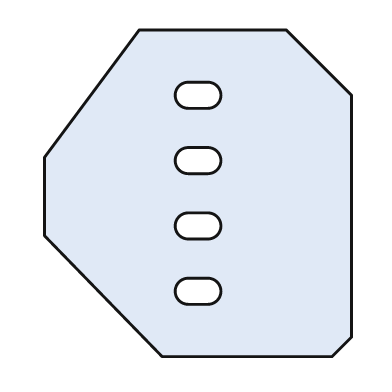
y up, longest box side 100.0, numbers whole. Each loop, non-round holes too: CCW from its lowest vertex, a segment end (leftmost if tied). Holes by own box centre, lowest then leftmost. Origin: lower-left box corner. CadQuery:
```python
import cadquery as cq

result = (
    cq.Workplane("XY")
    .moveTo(36.0, 0.0)
    .lineTo(88.0, 0.0)
    .lineTo(94.0, 6.0)
    .lineTo(94.0, 80.0)
    .lineTo(74.0, 100.0)
    .lineTo(29.0, 100.0)
    .lineTo(0.0, 61.0)
    .lineTo(0.0, 37.0)
    .close()
    .moveTo(44.0, 16.0)
    .lineTo(50.0, 16.0)
    .threePointArc((54.0, 20.0), (50.0, 24.0))
    .lineTo(44.0, 24.0)
    .threePointArc((40.0, 20.0), (44.0, 16.0))
    .close()
    .moveTo(44.0, 36.0)
    .lineTo(50.0, 36.0)
    .threePointArc((54.0, 40.0), (50.0, 44.0))
    .lineTo(44.0, 44.0)
    .threePointArc((40.0, 40.0), (44.0, 36.0))
    .close()
    .moveTo(44.0, 56.0)
    .lineTo(50.0, 56.0)
    .threePointArc((54.0, 60.0), (50.0, 64.0))
    .lineTo(44.0, 64.0)
    .threePointArc((40.0, 60.0), (44.0, 56.0))
    .close()
    .moveTo(44.0, 76.0)
    .lineTo(50.0, 76.0)
    .threePointArc((54.0, 80.0), (50.0, 84.0))
    .lineTo(44.0, 84.0)
    .threePointArc((40.0, 80.0), (44.0, 76.0))
    .close()
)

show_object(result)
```